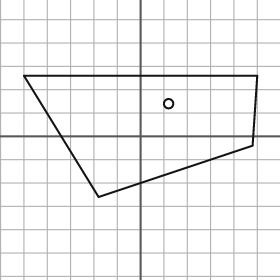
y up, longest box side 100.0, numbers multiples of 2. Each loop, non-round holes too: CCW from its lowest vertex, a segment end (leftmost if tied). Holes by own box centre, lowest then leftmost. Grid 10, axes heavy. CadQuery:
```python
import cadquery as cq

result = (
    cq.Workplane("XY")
    .moveTo(-18.0, -26.0)
    .lineTo(48.0, -4.0)
    .lineTo(50.0, 26.0)
    .lineTo(-50.0, 26.0)
    .close()
    .moveTo(12.0, 14.0)
    .circle(2.0)
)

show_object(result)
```